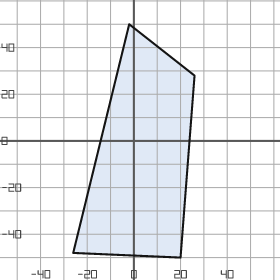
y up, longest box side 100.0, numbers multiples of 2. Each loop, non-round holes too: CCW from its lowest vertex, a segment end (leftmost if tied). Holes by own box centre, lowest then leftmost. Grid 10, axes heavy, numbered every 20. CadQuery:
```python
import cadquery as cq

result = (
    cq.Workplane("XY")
    .moveTo(20.0, -50.0)
    .lineTo(26.0, 28.0)
    .lineTo(-2.0, 50.0)
    .lineTo(-26.0, -48.0)
    .close()
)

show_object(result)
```